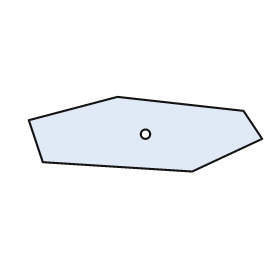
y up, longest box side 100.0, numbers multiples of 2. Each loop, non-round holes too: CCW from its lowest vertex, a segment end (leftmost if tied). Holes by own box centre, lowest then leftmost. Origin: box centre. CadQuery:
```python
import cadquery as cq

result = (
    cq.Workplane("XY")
    .moveTo(20.0, -16.0)
    .lineTo(50.0, -2.0)
    .lineTo(42.0, 10.0)
    .lineTo(-12.0, 16.0)
    .lineTo(-50.0, 6.0)
    .lineTo(-44.0, -12.0)
    .close()
    .moveTo(0.0, 0.0)
    .circle(2.0)
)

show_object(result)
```